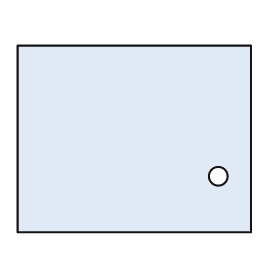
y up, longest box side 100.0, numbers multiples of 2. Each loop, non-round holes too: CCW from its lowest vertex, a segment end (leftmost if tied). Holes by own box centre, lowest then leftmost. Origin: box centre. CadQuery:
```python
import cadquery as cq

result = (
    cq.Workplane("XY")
    .moveTo(-50.0, -40.0)
    .lineTo(50.0, -40.0)
    .lineTo(50.0, 40.0)
    .lineTo(-50.0, 40.0)
    .close()
    .moveTo(36.0, -16.0)
    .circle(4.0)
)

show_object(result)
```